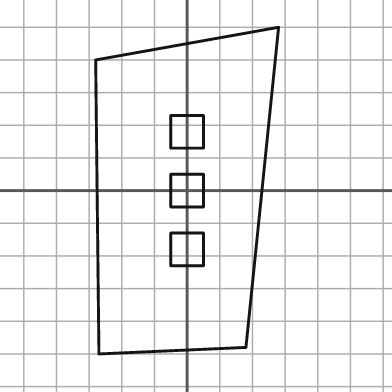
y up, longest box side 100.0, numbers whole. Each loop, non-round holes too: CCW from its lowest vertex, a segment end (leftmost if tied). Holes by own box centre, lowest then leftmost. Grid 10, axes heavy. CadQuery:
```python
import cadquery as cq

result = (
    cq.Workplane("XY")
    .moveTo(-27.0, -50.0)
    .lineTo(18.0, -48.0)
    .lineTo(28.0, 50.0)
    .lineTo(-28.0, 40.0)
    .close()
    .moveTo(-5.0, -23.0)
    .lineTo(5.0, -23.0)
    .lineTo(5.0, -13.0)
    .lineTo(-5.0, -13.0)
    .close()
    .moveTo(-5.0, -5.0)
    .lineTo(5.0, -5.0)
    .lineTo(5.0, 5.0)
    .lineTo(-5.0, 5.0)
    .close()
    .moveTo(-5.0, 13.0)
    .lineTo(5.0, 13.0)
    .lineTo(5.0, 23.0)
    .lineTo(-5.0, 23.0)
    .close()
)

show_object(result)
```